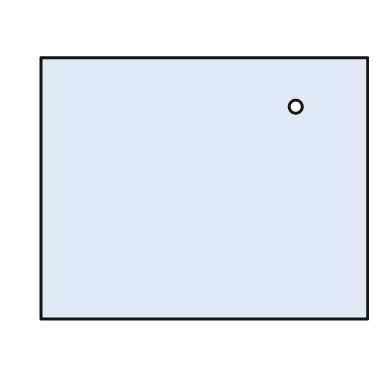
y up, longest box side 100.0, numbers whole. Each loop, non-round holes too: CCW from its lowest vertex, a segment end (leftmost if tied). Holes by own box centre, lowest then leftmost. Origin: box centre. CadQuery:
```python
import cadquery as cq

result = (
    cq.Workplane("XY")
    .moveTo(-50.0, -40.0)
    .lineTo(50.0, -40.0)
    .lineTo(50.0, 40.0)
    .lineTo(-50.0, 40.0)
    .close()
    .moveTo(28.0, 25.0)
    .circle(2.0)
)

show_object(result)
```